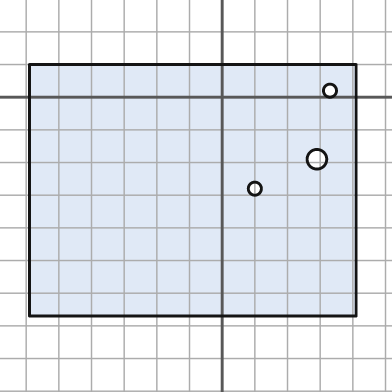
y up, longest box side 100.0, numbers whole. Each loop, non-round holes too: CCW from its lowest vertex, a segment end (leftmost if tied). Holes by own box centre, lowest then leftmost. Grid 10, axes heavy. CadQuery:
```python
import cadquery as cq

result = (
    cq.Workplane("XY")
    .moveTo(-59.0, -67.0)
    .lineTo(41.0, -67.0)
    .lineTo(41.0, 10.0)
    .lineTo(-59.0, 10.0)
    .close()
    .moveTo(10.0, -28.0)
    .circle(2.0)
    .moveTo(29.0, -19.0)
    .circle(3.0)
    .moveTo(33.0, 2.0)
    .circle(2.0)
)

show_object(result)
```